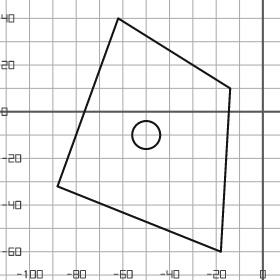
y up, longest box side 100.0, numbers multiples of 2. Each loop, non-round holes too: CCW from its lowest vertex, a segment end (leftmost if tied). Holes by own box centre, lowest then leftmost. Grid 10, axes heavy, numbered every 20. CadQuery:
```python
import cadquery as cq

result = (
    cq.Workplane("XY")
    .moveTo(-18.0, -60.0)
    .lineTo(-14.0, 10.0)
    .lineTo(-62.0, 40.0)
    .lineTo(-88.0, -32.0)
    .close()
    .moveTo(-50.0, -10.0)
    .circle(6.0)
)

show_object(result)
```